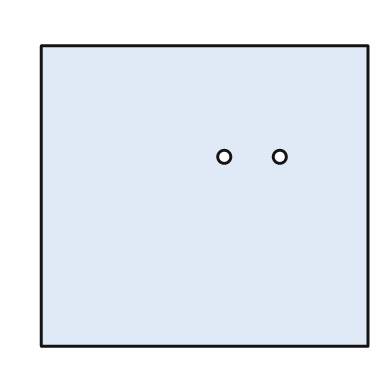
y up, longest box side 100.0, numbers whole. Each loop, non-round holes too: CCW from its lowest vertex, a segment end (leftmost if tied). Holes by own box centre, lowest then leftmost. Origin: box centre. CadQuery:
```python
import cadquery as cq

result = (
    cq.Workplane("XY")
    .moveTo(-50.0, -46.0)
    .lineTo(50.0, -46.0)
    .lineTo(50.0, 46.0)
    .lineTo(-50.0, 46.0)
    .close()
    .moveTo(6.0, 12.0)
    .circle(2.0)
    .moveTo(23.0, 12.0)
    .circle(2.0)
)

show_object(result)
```